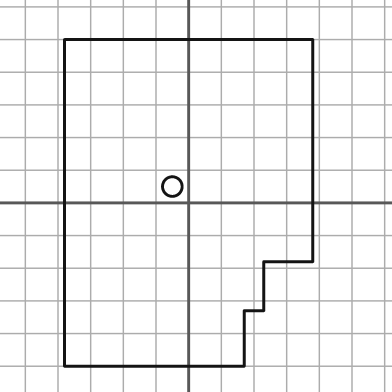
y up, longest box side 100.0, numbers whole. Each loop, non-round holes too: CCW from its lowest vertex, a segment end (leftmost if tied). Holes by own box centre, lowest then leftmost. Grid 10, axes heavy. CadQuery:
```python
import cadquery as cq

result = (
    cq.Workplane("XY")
    .moveTo(-38.0, -50.0)
    .lineTo(17.0, -50.0)
    .lineTo(17.0, -33.0)
    .lineTo(23.0, -33.0)
    .lineTo(23.0, -18.0)
    .lineTo(38.0, -18.0)
    .lineTo(38.0, 50.0)
    .lineTo(-38.0, 50.0)
    .close()
    .moveTo(-5.0, 5.0)
    .circle(3.0)
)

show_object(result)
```